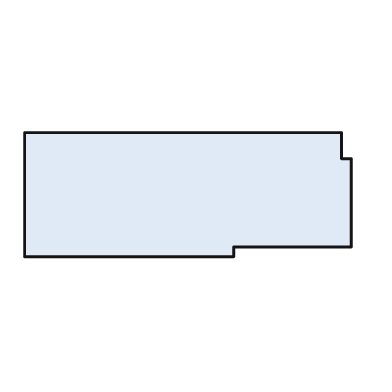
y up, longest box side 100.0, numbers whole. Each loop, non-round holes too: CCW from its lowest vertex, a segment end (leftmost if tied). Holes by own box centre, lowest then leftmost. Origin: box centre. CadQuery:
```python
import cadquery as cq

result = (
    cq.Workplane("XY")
    .moveTo(-50.0, -19.0)
    .lineTo(14.0, -19.0)
    .lineTo(14.0, -16.0)
    .lineTo(50.0, -16.0)
    .lineTo(50.0, 11.0)
    .lineTo(47.0, 11.0)
    .lineTo(47.0, 19.0)
    .lineTo(-50.0, 19.0)
    .close()
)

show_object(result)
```